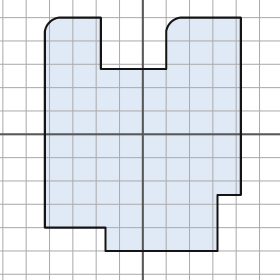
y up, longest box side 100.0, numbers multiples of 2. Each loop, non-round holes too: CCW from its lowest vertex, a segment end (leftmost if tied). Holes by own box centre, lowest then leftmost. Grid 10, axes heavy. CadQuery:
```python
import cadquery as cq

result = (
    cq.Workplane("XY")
    .moveTo(-16.0, -50.0)
    .lineTo(32.0, -50.0)
    .lineTo(32.0, -26.0)
    .lineTo(42.0, -26.0)
    .lineTo(42.0, 50.0)
    .lineTo(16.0, 50.0)
    .threePointArc((12.0, 48.0), (10.0, 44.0))
    .lineTo(10.0, 28.0)
    .lineTo(-18.0, 28.0)
    .lineTo(-18.0, 50.0)
    .lineTo(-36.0, 50.0)
    .threePointArc((-40.0, 48.0), (-42.0, 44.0))
    .lineTo(-42.0, -40.0)
    .lineTo(-16.0, -40.0)
    .close()
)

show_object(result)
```